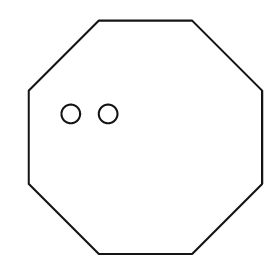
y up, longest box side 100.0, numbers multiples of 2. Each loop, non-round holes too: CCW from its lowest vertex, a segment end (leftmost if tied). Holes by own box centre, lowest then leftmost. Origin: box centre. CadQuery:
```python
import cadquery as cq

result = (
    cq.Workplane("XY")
    .moveTo(-20.0, -50.0)
    .lineTo(20.0, -50.0)
    .lineTo(50.0, -20.0)
    .lineTo(50.0, 20.0)
    .lineTo(20.0, 50.0)
    .lineTo(-20.0, 50.0)
    .lineTo(-50.0, 20.0)
    .lineTo(-50.0, -20.0)
    .close()
    .moveTo(-32.0, 10.0)
    .circle(4.0)
    .moveTo(-16.0, 10.0)
    .circle(4.0)
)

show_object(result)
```